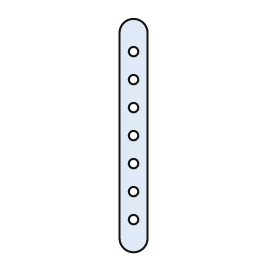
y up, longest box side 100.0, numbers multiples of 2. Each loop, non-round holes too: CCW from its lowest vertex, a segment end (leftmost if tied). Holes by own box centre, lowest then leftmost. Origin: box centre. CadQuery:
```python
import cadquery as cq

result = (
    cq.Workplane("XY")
    .moveTo(-6.0, -44.0)
    .threePointArc((0.0, -50.0), (6.0, -44.0))
    .lineTo(6.0, 44.0)
    .threePointArc((0.0, 50.0), (-6.0, 44.0))
    .close()
    .moveTo(0.0, -36.0)
    .circle(2.0)
    .moveTo(0.0, -24.0)
    .circle(2.0)
    .moveTo(0.0, -12.0)
    .circle(2.0)
    .moveTo(0.0, 0.0)
    .circle(2.0)
    .moveTo(0.0, 12.0)
    .circle(2.0)
    .moveTo(0.0, 24.0)
    .circle(2.0)
    .moveTo(0.0, 36.0)
    .circle(2.0)
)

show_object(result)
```